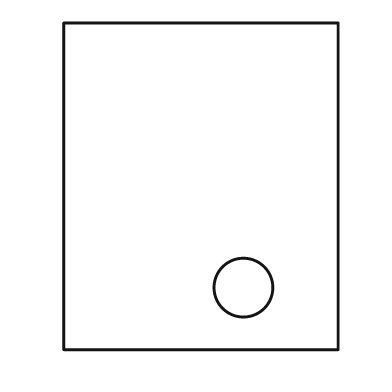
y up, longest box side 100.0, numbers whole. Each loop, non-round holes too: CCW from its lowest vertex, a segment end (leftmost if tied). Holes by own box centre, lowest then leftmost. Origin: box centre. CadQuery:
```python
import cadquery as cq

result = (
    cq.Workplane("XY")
    .moveTo(-42.0, -50.0)
    .lineTo(42.0, -50.0)
    .lineTo(42.0, 50.0)
    .lineTo(-42.0, 50.0)
    .close()
    .moveTo(13.0, -31.0)
    .circle(9.0)
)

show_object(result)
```